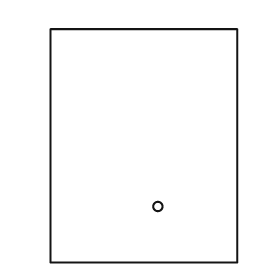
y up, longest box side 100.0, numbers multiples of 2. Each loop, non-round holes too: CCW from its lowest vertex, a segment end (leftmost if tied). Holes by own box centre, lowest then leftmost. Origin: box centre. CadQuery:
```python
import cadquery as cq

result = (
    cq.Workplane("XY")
    .moveTo(-40.0, -50.0)
    .lineTo(40.0, -50.0)
    .lineTo(40.0, 50.0)
    .lineTo(-40.0, 50.0)
    .close()
    .moveTo(6.0, -26.0)
    .circle(2.0)
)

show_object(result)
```